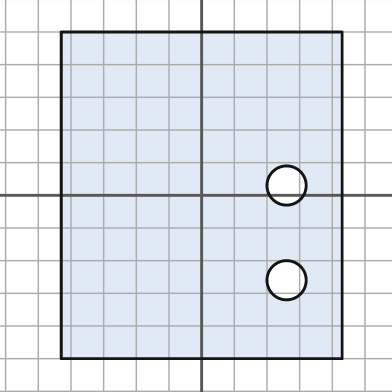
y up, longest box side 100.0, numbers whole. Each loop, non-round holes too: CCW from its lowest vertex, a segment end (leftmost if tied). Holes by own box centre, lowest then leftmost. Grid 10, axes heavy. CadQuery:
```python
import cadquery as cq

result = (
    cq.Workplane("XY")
    .moveTo(-43.0, -50.0)
    .lineTo(43.0, -50.0)
    .lineTo(43.0, 50.0)
    .lineTo(-43.0, 50.0)
    .close()
    .moveTo(26.0, -26.0)
    .circle(6.0)
    .moveTo(26.0, 3.0)
    .circle(6.0)
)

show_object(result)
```